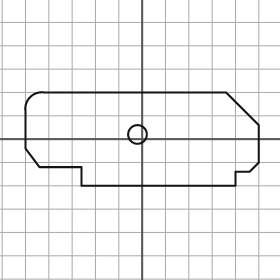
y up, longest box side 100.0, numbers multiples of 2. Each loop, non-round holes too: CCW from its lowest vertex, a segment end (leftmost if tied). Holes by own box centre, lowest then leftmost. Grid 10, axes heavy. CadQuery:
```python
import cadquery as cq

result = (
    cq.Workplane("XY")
    .moveTo(-26.0, -20.0)
    .lineTo(40.0, -20.0)
    .lineTo(40.0, -14.0)
    .lineTo(46.0, -14.0)
    .lineTo(50.0, -10.0)
    .lineTo(50.0, 6.0)
    .lineTo(36.0, 20.0)
    .lineTo(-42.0, 20.0)
    .threePointArc((-48.0, 18.0), (-50.0, 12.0))
    .lineTo(-50.0, -4.0)
    .lineTo(-44.0, -12.0)
    .lineTo(-26.0, -12.0)
    .close()
    .moveTo(-2.0, 2.0)
    .circle(4.0)
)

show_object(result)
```